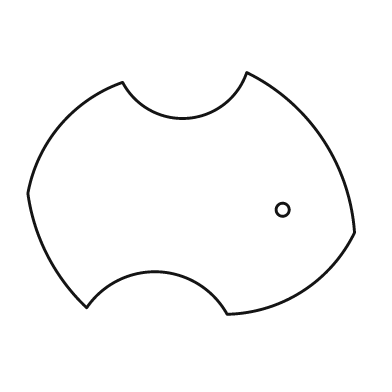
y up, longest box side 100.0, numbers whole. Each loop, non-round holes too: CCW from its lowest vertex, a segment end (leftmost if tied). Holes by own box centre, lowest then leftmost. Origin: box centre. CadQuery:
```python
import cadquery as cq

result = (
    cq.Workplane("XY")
    .moveTo(11.0, -37.0)
    .threePointArc((34.0, -30.0), (50.0, -12.0))
    .threePointArc((40.0, 17.0), (17.0, 37.0))
    .threePointArc((-1.0, 23.0), (-21.0, 34.0))
    .threePointArc((-40.0, 21.0), (-50.0, 0.0))
    .threePointArc((-44.0, -19.0), (-32.0, -35.0))
    .threePointArc((-10.0, -24.0), (11.0, -37.0))
    .close()
    .moveTo(28.0, -5.0)
    .circle(2.0)
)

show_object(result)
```